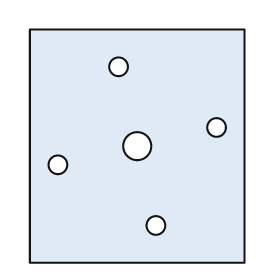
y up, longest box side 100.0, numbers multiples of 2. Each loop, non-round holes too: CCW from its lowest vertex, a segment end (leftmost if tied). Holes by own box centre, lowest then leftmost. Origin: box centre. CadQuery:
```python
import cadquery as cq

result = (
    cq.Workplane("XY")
    .moveTo(-46.0, -50.0)
    .lineTo(46.0, -50.0)
    .lineTo(46.0, 50.0)
    .lineTo(-46.0, 50.0)
    .close()
    .moveTo(8.0, -34.0)
    .circle(4.0)
    .moveTo(-34.0, -8.0)
    .circle(4.0)
    .moveTo(0.0, 0.0)
    .circle(6.0)
    .moveTo(34.0, 8.0)
    .circle(4.0)
    .moveTo(-8.0, 34.0)
    .circle(4.0)
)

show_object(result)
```